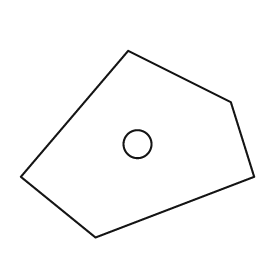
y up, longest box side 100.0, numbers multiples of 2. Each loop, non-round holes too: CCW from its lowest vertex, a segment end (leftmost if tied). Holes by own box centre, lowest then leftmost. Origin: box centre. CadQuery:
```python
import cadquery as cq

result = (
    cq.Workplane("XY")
    .moveTo(-18.0, -40.0)
    .lineTo(50.0, -14.0)
    .lineTo(40.0, 18.0)
    .lineTo(-4.0, 40.0)
    .lineTo(-50.0, -14.0)
    .close()
    .moveTo(0.0, 0.0)
    .circle(6.0)
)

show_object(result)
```